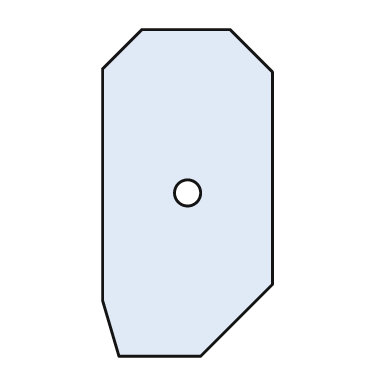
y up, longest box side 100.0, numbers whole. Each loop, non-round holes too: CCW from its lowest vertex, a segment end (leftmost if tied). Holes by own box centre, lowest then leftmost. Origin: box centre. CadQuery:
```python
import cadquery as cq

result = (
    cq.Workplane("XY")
    .moveTo(-21.0, -50.0)
    .lineTo(4.0, -50.0)
    .lineTo(26.0, -28.0)
    .lineTo(26.0, 37.0)
    .lineTo(13.0, 50.0)
    .lineTo(-14.0, 50.0)
    .lineTo(-26.0, 38.0)
    .lineTo(-26.0, -33.0)
    .close()
    .moveTo(0.0, 0.0)
    .circle(4.0)
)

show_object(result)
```